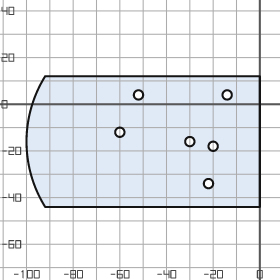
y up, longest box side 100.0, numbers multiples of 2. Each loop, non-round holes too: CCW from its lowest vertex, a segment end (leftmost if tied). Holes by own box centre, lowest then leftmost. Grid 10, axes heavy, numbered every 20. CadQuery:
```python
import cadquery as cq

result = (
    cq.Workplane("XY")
    .moveTo(-92.0, -44.0)
    .lineTo(0.0, -44.0)
    .lineTo(0.0, 12.0)
    .lineTo(-92.0, 12.0)
    .threePointArc((-100.0, -16.0), (-92.0, -44.0))
    .close()
    .moveTo(-22.0, -34.0)
    .circle(2.0)
    .moveTo(-20.0, -18.0)
    .circle(2.0)
    .moveTo(-30.0, -16.0)
    .circle(2.0)
    .moveTo(-60.0, -12.0)
    .circle(2.0)
    .moveTo(-52.0, 4.0)
    .circle(2.0)
    .moveTo(-14.0, 4.0)
    .circle(2.0)
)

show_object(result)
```